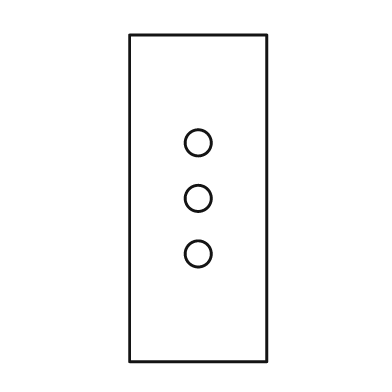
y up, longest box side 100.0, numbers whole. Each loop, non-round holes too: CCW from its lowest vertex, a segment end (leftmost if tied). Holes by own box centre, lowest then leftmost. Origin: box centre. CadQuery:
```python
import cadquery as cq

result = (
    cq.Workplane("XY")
    .moveTo(-21.0, -50.0)
    .lineTo(21.0, -50.0)
    .lineTo(21.0, 50.0)
    .lineTo(-21.0, 50.0)
    .close()
    .moveTo(0.0, -17.0)
    .circle(4.0)
    .moveTo(0.0, 0.0)
    .circle(4.0)
    .moveTo(0.0, 17.0)
    .circle(4.0)
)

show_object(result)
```